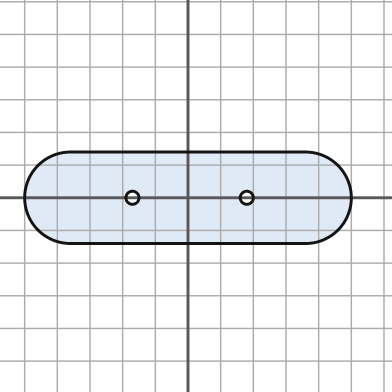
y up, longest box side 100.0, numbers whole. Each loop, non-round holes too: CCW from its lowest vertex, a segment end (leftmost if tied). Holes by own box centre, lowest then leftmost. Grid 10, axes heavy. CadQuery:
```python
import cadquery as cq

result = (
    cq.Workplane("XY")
    .moveTo(-36.0, -14.0)
    .lineTo(36.0, -14.0)
    .threePointArc((50.0, 0.0), (36.0, 14.0))
    .lineTo(-36.0, 14.0)
    .threePointArc((-50.0, 0.0), (-36.0, -14.0))
    .close()
    .moveTo(-17.0, 0.0)
    .circle(2.0)
    .moveTo(18.0, 0.0)
    .circle(2.0)
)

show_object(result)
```